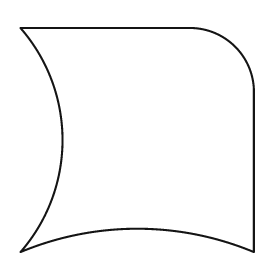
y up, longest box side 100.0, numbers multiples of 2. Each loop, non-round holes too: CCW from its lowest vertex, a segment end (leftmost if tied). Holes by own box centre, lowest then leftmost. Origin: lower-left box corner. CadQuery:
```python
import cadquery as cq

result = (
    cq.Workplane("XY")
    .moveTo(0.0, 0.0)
    .threePointArc((50.0, 10.0), (100.0, 0.0))
    .lineTo(100.0, 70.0)
    .threePointArc((92.0, 88.0), (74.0, 96.0))
    .lineTo(0.0, 96.0)
    .threePointArc((18.0, 48.0), (0.0, 0.0))
    .close()
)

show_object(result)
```